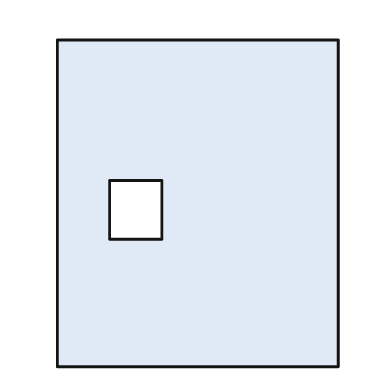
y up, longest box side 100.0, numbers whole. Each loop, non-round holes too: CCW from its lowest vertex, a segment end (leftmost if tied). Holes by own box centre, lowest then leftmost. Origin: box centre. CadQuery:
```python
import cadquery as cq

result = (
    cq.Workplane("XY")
    .moveTo(-43.0, -50.0)
    .lineTo(43.0, -50.0)
    .lineTo(43.0, 50.0)
    .lineTo(-43.0, 50.0)
    .close()
    .moveTo(-27.0, -11.0)
    .lineTo(-11.0, -11.0)
    .lineTo(-11.0, 7.0)
    .lineTo(-27.0, 7.0)
    .close()
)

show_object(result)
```